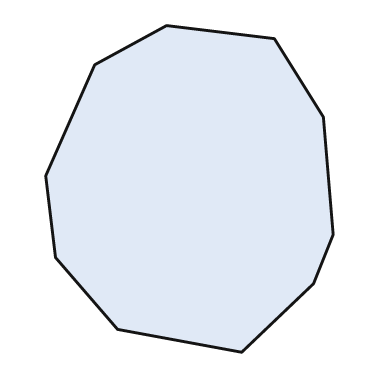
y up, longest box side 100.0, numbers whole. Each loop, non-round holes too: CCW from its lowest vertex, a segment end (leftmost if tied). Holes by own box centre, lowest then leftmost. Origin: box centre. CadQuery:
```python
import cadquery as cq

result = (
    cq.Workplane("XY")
    .moveTo(16.0, -50.0)
    .lineTo(38.0, -29.0)
    .lineTo(44.0, -14.0)
    .lineTo(41.0, 22.0)
    .lineTo(26.0, 46.0)
    .lineTo(-7.0, 50.0)
    .lineTo(-29.0, 38.0)
    .lineTo(-44.0, 4.0)
    .lineTo(-41.0, -21.0)
    .lineTo(-22.0, -43.0)
    .close()
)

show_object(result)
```